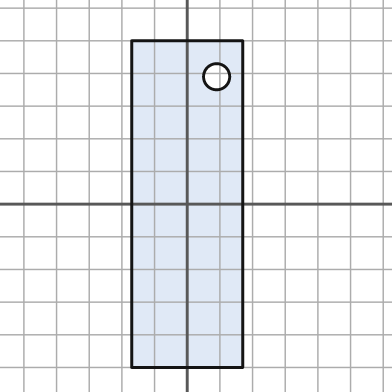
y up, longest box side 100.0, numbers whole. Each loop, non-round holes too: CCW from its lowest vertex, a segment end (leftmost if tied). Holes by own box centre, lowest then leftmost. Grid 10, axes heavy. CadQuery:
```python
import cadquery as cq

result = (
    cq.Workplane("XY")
    .moveTo(-17.0, -50.0)
    .lineTo(17.0, -50.0)
    .lineTo(17.0, 50.0)
    .lineTo(-17.0, 50.0)
    .close()
    .moveTo(9.0, 39.0)
    .circle(4.0)
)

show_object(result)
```